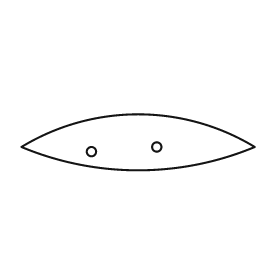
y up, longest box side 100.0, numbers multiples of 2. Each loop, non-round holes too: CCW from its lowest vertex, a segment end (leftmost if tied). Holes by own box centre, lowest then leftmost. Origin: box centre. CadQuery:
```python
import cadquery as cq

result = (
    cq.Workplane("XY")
    .moveTo(-50.0, -2.0)
    .threePointArc((0.0, -12.0), (50.0, -2.0))
    .threePointArc((0.0, 12.0), (-50.0, -2.0))
    .close()
    .moveTo(-20.0, -4.0)
    .circle(2.0)
    .moveTo(8.0, -2.0)
    .circle(2.0)
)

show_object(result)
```